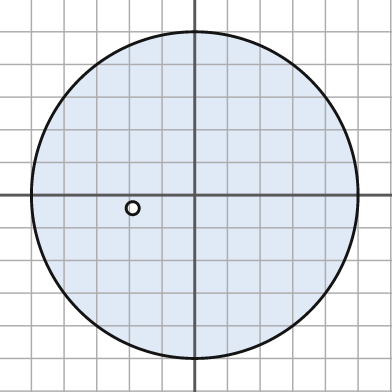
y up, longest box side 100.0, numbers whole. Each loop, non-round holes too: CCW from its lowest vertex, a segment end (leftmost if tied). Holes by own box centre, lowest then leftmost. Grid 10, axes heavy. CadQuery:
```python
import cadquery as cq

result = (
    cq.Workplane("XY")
    .moveTo(0.0, 0.0)
    .circle(50.0)
    .moveTo(-19.0, -4.0)
    .circle(2.0)
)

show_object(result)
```